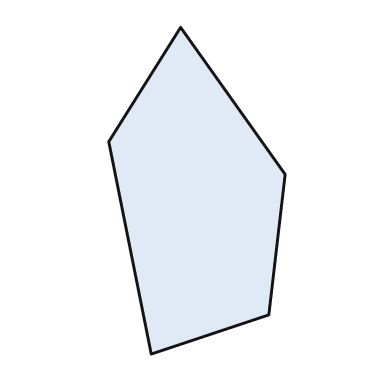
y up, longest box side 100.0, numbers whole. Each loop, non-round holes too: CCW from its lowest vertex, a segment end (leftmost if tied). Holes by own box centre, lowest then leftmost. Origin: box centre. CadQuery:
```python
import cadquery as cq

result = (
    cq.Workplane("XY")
    .moveTo(-14.0, -50.0)
    .lineTo(22.0, -38.0)
    .lineTo(27.0, 5.0)
    .lineTo(-5.0, 50.0)
    .lineTo(-27.0, 15.0)
    .close()
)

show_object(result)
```